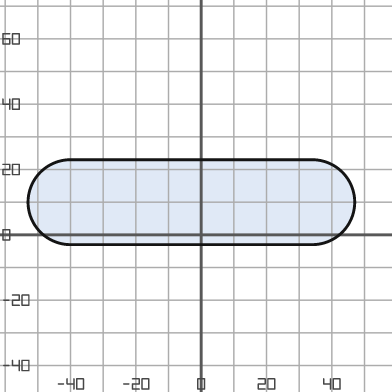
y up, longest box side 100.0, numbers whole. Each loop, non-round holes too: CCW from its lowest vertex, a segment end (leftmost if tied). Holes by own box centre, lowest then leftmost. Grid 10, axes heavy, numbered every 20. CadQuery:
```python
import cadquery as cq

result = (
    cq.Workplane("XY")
    .moveTo(-40.0, -3.0)
    .lineTo(34.0, -3.0)
    .threePointArc((47.0, 10.0), (34.0, 23.0))
    .lineTo(-40.0, 23.0)
    .threePointArc((-53.0, 10.0), (-40.0, -3.0))
    .close()
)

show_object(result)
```